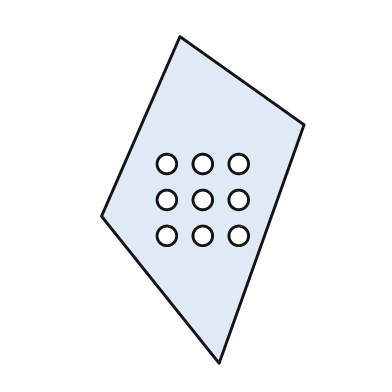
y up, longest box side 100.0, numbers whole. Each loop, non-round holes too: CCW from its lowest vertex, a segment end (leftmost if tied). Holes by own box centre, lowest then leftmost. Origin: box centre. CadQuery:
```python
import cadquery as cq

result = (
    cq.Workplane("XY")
    .moveTo(5.0, -50.0)
    .lineTo(31.0, 23.0)
    .lineTo(-7.0, 50.0)
    .lineTo(-31.0, -5.0)
    .close()
    .moveTo(-11.0, -11.0)
    .circle(3.0)
    .moveTo(0.0, -11.0)
    .circle(3.0)
    .moveTo(11.0, -11.0)
    .circle(3.0)
    .moveTo(-11.0, 0.0)
    .circle(3.0)
    .moveTo(0.0, 0.0)
    .circle(3.0)
    .moveTo(11.0, 0.0)
    .circle(3.0)
    .moveTo(-11.0, 11.0)
    .circle(3.0)
    .moveTo(0.0, 11.0)
    .circle(3.0)
    .moveTo(11.0, 11.0)
    .circle(3.0)
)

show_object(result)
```